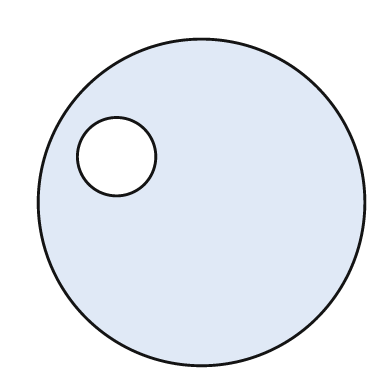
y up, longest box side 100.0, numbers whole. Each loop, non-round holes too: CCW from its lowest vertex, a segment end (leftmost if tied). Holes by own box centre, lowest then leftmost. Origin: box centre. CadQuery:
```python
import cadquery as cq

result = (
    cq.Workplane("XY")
    .moveTo(0.0, 0.0)
    .circle(50.0)
    .moveTo(-26.0, 14.0)
    .circle(12.0)
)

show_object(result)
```